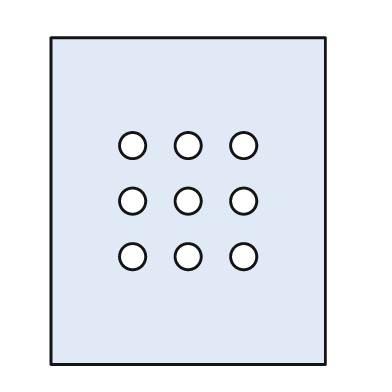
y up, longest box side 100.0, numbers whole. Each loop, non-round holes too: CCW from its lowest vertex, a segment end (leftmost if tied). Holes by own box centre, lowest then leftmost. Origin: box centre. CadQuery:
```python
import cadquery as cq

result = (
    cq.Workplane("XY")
    .moveTo(-42.0, -50.0)
    .lineTo(42.0, -50.0)
    .lineTo(42.0, 50.0)
    .lineTo(-42.0, 50.0)
    .close()
    .moveTo(-17.0, -17.0)
    .circle(4.0)
    .moveTo(0.0, -17.0)
    .circle(4.0)
    .moveTo(17.0, -17.0)
    .circle(4.0)
    .moveTo(-17.0, 0.0)
    .circle(4.0)
    .moveTo(0.0, 0.0)
    .circle(4.0)
    .moveTo(17.0, 0.0)
    .circle(4.0)
    .moveTo(-17.0, 17.0)
    .circle(4.0)
    .moveTo(0.0, 17.0)
    .circle(4.0)
    .moveTo(17.0, 17.0)
    .circle(4.0)
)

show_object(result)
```